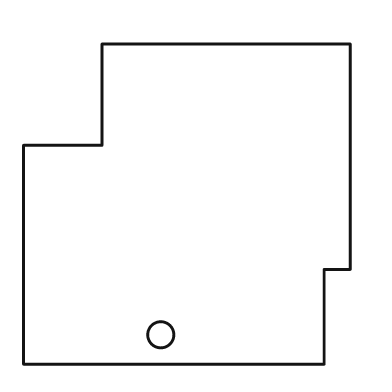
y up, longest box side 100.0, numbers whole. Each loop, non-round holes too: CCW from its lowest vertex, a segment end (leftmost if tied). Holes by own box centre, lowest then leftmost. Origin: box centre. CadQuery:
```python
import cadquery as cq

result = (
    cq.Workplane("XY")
    .moveTo(-50.0, -49.0)
    .lineTo(42.0, -49.0)
    .lineTo(42.0, -20.0)
    .lineTo(50.0, -20.0)
    .lineTo(50.0, 49.0)
    .lineTo(-26.0, 49.0)
    .lineTo(-26.0, 18.0)
    .lineTo(-50.0, 18.0)
    .close()
    .moveTo(-8.0, -40.0)
    .circle(4.0)
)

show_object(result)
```